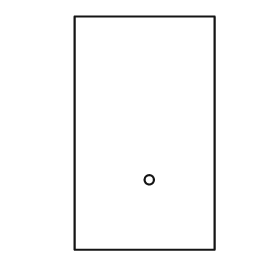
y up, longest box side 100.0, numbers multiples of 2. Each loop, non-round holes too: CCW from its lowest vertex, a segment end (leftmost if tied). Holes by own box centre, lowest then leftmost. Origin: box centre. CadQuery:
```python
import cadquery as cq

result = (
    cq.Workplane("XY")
    .moveTo(-30.0, -50.0)
    .lineTo(30.0, -50.0)
    .lineTo(30.0, 50.0)
    .lineTo(-30.0, 50.0)
    .close()
    .moveTo(2.0, -20.0)
    .circle(2.0)
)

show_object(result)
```